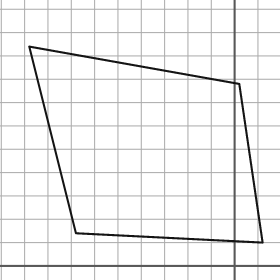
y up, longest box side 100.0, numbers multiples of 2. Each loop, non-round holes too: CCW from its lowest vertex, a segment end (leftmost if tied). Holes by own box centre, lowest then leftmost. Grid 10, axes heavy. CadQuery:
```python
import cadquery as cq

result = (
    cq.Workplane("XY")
    .moveTo(12.0, 10.0)
    .lineTo(2.0, 78.0)
    .lineTo(-88.0, 94.0)
    .lineTo(-68.0, 14.0)
    .close()
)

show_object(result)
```